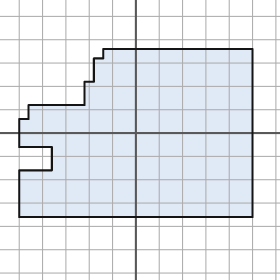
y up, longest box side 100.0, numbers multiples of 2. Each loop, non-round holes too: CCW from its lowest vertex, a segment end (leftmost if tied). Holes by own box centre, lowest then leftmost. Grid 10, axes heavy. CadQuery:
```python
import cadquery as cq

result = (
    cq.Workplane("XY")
    .moveTo(-50.0, -36.0)
    .lineTo(50.0, -36.0)
    .lineTo(50.0, 36.0)
    .lineTo(-14.0, 36.0)
    .lineTo(-14.0, 32.0)
    .lineTo(-18.0, 32.0)
    .lineTo(-18.0, 22.0)
    .lineTo(-22.0, 22.0)
    .lineTo(-22.0, 12.0)
    .lineTo(-46.0, 12.0)
    .lineTo(-46.0, 6.0)
    .lineTo(-50.0, 6.0)
    .lineTo(-50.0, -6.0)
    .lineTo(-36.0, -6.0)
    .lineTo(-36.0, -16.0)
    .lineTo(-50.0, -16.0)
    .close()
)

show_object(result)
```